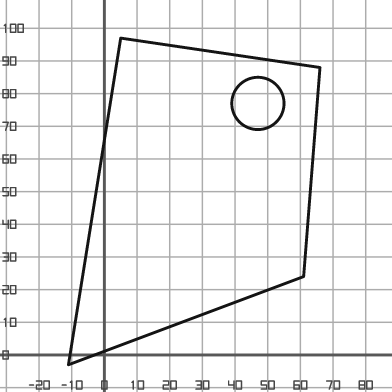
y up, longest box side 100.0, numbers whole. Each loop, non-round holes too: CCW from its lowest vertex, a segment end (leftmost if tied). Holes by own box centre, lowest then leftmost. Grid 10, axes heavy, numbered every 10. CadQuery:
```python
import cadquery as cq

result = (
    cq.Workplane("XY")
    .moveTo(-11.0, -3.0)
    .lineTo(61.0, 24.0)
    .lineTo(66.0, 88.0)
    .lineTo(5.0, 97.0)
    .close()
    .moveTo(47.0, 77.0)
    .circle(8.0)
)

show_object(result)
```